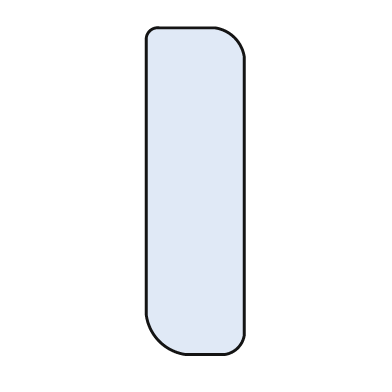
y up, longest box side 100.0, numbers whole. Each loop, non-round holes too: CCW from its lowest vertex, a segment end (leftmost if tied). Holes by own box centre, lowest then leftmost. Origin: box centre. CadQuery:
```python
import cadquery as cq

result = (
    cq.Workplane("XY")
    .moveTo(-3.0, -50.0)
    .lineTo(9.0, -50.0)
    .threePointArc((13.0, -48.0), (15.0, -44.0))
    .lineTo(15.0, 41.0)
    .threePointArc((12.0, 47.0), (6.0, 50.0))
    .lineTo(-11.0, 50.0)
    .threePointArc((-14.0, 49.0), (-15.0, 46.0))
    .lineTo(-15.0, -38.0)
    .threePointArc((-11.0, -46.0), (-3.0, -50.0))
    .close()
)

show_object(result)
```